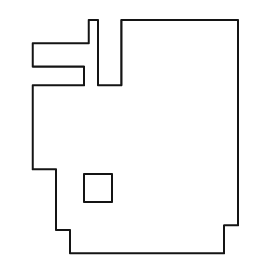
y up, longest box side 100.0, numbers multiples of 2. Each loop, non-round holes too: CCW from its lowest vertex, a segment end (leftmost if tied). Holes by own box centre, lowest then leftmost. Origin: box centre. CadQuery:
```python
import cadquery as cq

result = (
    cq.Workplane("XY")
    .moveTo(-28.0, -50.0)
    .lineTo(38.0, -50.0)
    .lineTo(38.0, -38.0)
    .lineTo(44.0, -38.0)
    .lineTo(44.0, 50.0)
    .lineTo(-6.0, 50.0)
    .lineTo(-6.0, 22.0)
    .lineTo(-16.0, 22.0)
    .lineTo(-16.0, 50.0)
    .lineTo(-20.0, 50.0)
    .lineTo(-20.0, 40.0)
    .lineTo(-44.0, 40.0)
    .lineTo(-44.0, 30.0)
    .lineTo(-22.0, 30.0)
    .lineTo(-22.0, 22.0)
    .lineTo(-44.0, 22.0)
    .lineTo(-44.0, -14.0)
    .lineTo(-34.0, -14.0)
    .lineTo(-34.0, -40.0)
    .lineTo(-28.0, -40.0)
    .close()
    .moveTo(-22.0, -28.0)
    .lineTo(-10.0, -28.0)
    .lineTo(-10.0, -16.0)
    .lineTo(-22.0, -16.0)
    .close()
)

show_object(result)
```